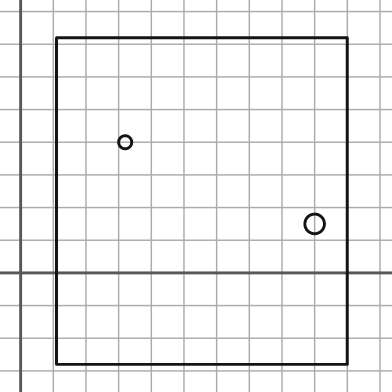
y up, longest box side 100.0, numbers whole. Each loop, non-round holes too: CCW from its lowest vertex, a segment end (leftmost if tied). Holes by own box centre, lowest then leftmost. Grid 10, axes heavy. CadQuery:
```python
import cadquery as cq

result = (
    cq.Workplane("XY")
    .moveTo(11.0, -28.0)
    .lineTo(100.0, -28.0)
    .lineTo(100.0, 72.0)
    .lineTo(11.0, 72.0)
    .close()
    .moveTo(90.0, 15.0)
    .circle(3.0)
    .moveTo(32.0, 40.0)
    .circle(2.0)
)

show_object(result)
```